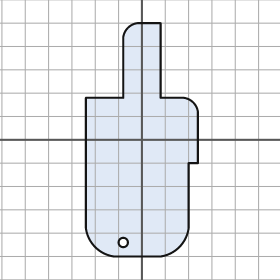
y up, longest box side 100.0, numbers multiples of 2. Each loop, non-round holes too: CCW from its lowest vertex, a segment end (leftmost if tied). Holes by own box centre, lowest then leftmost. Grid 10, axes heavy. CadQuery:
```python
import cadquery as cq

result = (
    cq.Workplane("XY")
    .moveTo(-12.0, -50.0)
    .lineTo(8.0, -50.0)
    .threePointArc((16.0, -46.0), (20.0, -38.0))
    .lineTo(20.0, -10.0)
    .lineTo(24.0, -10.0)
    .lineTo(24.0, 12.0)
    .threePointArc((22.0, 16.0), (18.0, 18.0))
    .lineTo(8.0, 18.0)
    .lineTo(8.0, 50.0)
    .lineTo(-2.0, 50.0)
    .threePointArc((-6.0, 48.0), (-8.0, 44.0))
    .lineTo(-8.0, 18.0)
    .lineTo(-24.0, 18.0)
    .lineTo(-24.0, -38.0)
    .threePointArc((-20.0, -46.0), (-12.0, -50.0))
    .close()
    .moveTo(-8.0, -44.0)
    .circle(2.0)
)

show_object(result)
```